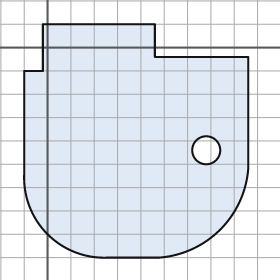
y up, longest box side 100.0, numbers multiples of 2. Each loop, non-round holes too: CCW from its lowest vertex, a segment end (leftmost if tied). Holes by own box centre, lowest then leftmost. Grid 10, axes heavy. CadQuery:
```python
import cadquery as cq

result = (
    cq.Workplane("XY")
    .moveTo(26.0, -90.0)
    .lineTo(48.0, -90.0)
    .threePointArc((74.0, -78.0), (86.0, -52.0))
    .lineTo(86.0, -4.0)
    .lineTo(46.0, -4.0)
    .lineTo(46.0, 10.0)
    .lineTo(-2.0, 10.0)
    .lineTo(-2.0, -10.0)
    .lineTo(-10.0, -10.0)
    .lineTo(-10.0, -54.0)
    .threePointArc((0.0, -80.0), (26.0, -90.0))
    .close()
    .moveTo(68.0, -44.0)
    .circle(6.0)
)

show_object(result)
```